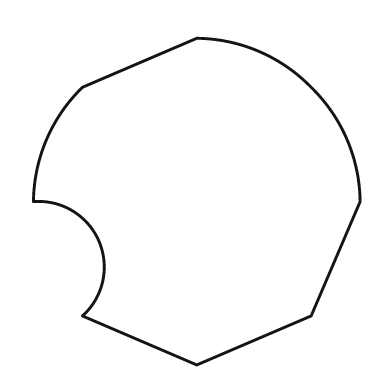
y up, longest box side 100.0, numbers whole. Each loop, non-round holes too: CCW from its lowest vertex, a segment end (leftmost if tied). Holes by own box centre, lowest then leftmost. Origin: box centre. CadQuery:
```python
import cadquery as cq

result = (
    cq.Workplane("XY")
    .moveTo(0.0, -50.0)
    .lineTo(35.0, -35.0)
    .lineTo(50.0, 0.0)
    .threePointArc((46.0, 19.0), (35.0, 35.0))
    .threePointArc((19.0, 46.0), (0.0, 50.0))
    .lineTo(-35.0, 35.0)
    .threePointArc((-46.0, 19.0), (-50.0, 0.0))
    .threePointArc((-30.0, -12.0), (-35.0, -35.0))
    .close()
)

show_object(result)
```